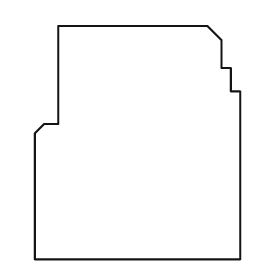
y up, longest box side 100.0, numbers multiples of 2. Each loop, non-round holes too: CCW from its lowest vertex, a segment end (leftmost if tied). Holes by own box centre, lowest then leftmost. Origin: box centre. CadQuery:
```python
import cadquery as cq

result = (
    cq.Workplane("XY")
    .moveTo(-44.0, -50.0)
    .lineTo(44.0, -50.0)
    .lineTo(44.0, 22.0)
    .lineTo(40.0, 22.0)
    .lineTo(40.0, 32.0)
    .lineTo(36.0, 32.0)
    .lineTo(36.0, 44.0)
    .lineTo(30.0, 50.0)
    .lineTo(-34.0, 50.0)
    .lineTo(-34.0, 8.0)
    .lineTo(-40.0, 8.0)
    .lineTo(-44.0, 4.0)
    .close()
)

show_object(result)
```